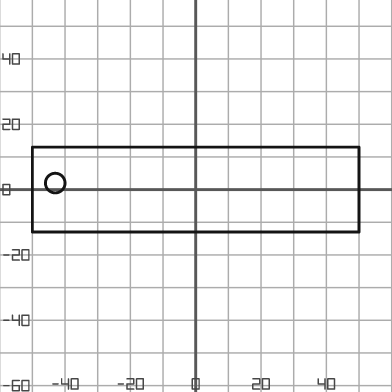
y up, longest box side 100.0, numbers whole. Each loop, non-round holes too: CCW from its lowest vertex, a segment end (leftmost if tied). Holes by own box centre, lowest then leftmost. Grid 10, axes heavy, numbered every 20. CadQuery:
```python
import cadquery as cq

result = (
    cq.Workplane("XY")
    .moveTo(-50.0, -13.0)
    .lineTo(50.0, -13.0)
    .lineTo(50.0, 13.0)
    .lineTo(-50.0, 13.0)
    .close()
    .moveTo(-43.0, 2.0)
    .circle(3.0)
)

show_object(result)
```